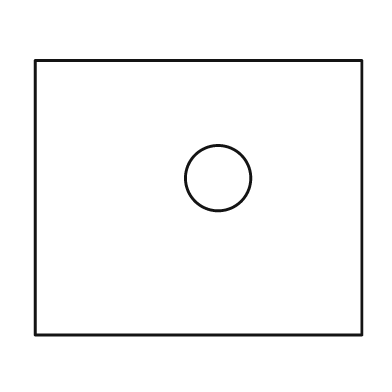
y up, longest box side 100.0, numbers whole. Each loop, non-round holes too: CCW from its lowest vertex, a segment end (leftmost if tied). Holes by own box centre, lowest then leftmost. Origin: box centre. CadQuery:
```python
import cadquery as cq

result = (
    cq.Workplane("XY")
    .moveTo(-50.0, -42.0)
    .lineTo(50.0, -42.0)
    .lineTo(50.0, 42.0)
    .lineTo(-50.0, 42.0)
    .close()
    .moveTo(6.0, 6.0)
    .circle(10.0)
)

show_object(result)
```